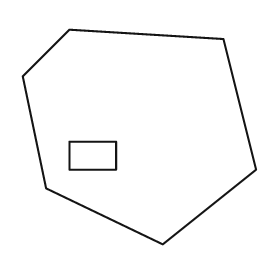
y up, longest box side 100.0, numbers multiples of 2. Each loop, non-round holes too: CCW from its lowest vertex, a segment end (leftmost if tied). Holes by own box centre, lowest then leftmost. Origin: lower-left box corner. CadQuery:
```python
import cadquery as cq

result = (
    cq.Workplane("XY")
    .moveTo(60.0, 0.0)
    .lineTo(100.0, 32.0)
    .lineTo(86.0, 88.0)
    .lineTo(20.0, 92.0)
    .lineTo(0.0, 72.0)
    .lineTo(10.0, 24.0)
    .close()
    .moveTo(20.0, 32.0)
    .lineTo(40.0, 32.0)
    .lineTo(40.0, 44.0)
    .lineTo(20.0, 44.0)
    .close()
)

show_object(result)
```